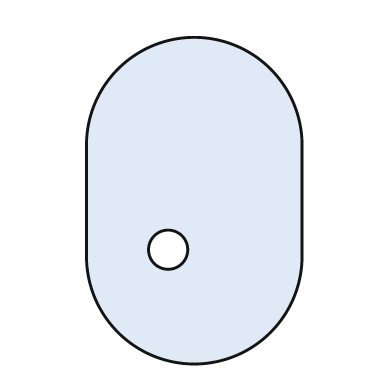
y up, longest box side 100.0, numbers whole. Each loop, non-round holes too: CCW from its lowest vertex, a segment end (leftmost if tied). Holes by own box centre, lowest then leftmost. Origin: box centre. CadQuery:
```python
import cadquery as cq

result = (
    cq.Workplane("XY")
    .moveTo(-33.0, -17.0)
    .threePointArc((0.0, -50.0), (33.0, -17.0))
    .lineTo(33.0, 17.0)
    .threePointArc((0.0, 50.0), (-33.0, 17.0))
    .close()
    .moveTo(-8.0, -15.0)
    .circle(6.0)
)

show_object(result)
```